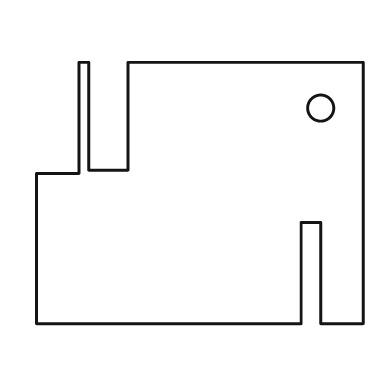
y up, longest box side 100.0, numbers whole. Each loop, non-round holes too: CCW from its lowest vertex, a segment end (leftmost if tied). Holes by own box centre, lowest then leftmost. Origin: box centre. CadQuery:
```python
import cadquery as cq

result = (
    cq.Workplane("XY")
    .moveTo(-50.0, -40.0)
    .lineTo(31.0, -40.0)
    .lineTo(31.0, -9.0)
    .lineTo(37.0, -9.0)
    .lineTo(37.0, -40.0)
    .lineTo(50.0, -40.0)
    .lineTo(50.0, 40.0)
    .lineTo(-22.0, 40.0)
    .lineTo(-22.0, 7.0)
    .lineTo(-34.0, 7.0)
    .lineTo(-34.0, 40.0)
    .lineTo(-37.0, 40.0)
    .lineTo(-37.0, 6.0)
    .lineTo(-50.0, 6.0)
    .close()
    .moveTo(37.0, 26.0)
    .circle(4.0)
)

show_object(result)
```